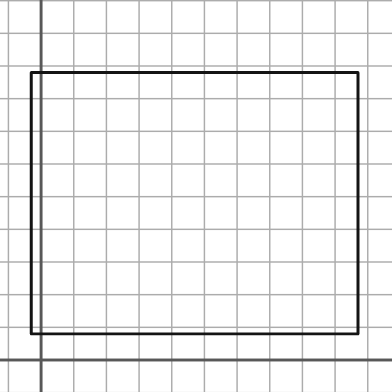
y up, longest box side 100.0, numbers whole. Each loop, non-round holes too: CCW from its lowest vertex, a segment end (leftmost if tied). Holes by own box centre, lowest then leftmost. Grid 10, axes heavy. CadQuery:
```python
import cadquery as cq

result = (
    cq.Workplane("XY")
    .moveTo(-3.0, 8.0)
    .lineTo(97.0, 8.0)
    .lineTo(97.0, 88.0)
    .lineTo(-3.0, 88.0)
    .close()
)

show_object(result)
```